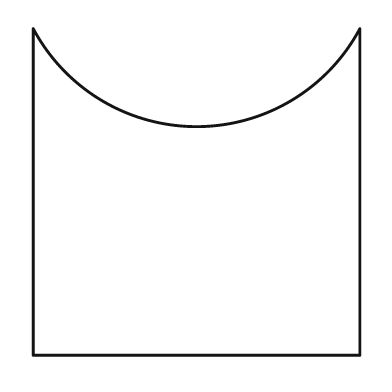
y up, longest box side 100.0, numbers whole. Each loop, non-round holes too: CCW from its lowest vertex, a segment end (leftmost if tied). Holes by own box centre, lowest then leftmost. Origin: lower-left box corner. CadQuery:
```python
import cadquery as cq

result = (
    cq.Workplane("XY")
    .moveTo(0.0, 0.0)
    .lineTo(100.0, 0.0)
    .lineTo(100.0, 100.0)
    .threePointArc((50.0, 70.0), (0.0, 100.0))
    .close()
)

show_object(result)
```